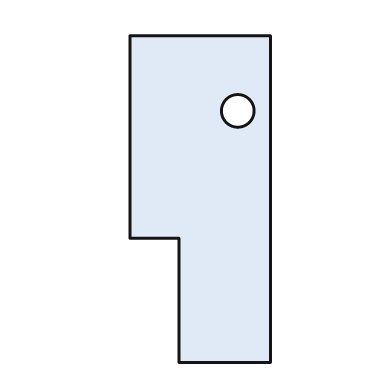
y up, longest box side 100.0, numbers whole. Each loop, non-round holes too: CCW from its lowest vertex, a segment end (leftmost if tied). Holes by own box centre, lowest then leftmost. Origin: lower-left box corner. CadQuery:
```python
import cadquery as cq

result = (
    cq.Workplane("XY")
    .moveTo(15.0, 0.0)
    .lineTo(43.0, 0.0)
    .lineTo(43.0, 100.0)
    .lineTo(0.0, 100.0)
    .lineTo(0.0, 38.0)
    .lineTo(15.0, 38.0)
    .close()
    .moveTo(33.0, 77.0)
    .circle(5.0)
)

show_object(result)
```